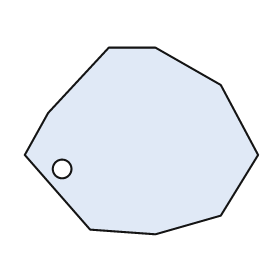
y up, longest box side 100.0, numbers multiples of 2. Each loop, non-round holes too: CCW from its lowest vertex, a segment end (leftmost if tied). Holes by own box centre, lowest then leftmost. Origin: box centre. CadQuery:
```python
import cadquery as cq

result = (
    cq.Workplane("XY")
    .moveTo(6.0, -40.0)
    .lineTo(34.0, -32.0)
    .lineTo(50.0, -6.0)
    .lineTo(34.0, 24.0)
    .lineTo(6.0, 40.0)
    .lineTo(-14.0, 40.0)
    .lineTo(-40.0, 12.0)
    .lineTo(-50.0, -6.0)
    .lineTo(-22.0, -38.0)
    .close()
    .moveTo(-34.0, -12.0)
    .circle(4.0)
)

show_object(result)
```